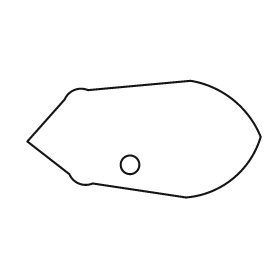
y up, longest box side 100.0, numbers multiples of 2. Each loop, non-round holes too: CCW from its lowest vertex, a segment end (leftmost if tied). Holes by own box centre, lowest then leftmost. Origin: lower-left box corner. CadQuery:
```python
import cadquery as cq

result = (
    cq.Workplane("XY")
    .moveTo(68.0, 0.0)
    .threePointArc((88.0, 8.0), (100.0, 26.0))
    .threePointArc((88.0, 42.0), (70.0, 50.0))
    .lineTo(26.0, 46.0)
    .threePointArc((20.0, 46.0), (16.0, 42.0))
    .lineTo(0.0, 24.0)
    .lineTo(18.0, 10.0)
    .threePointArc((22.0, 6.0), (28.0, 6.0))
    .close()
    .moveTo(44.0, 14.0)
    .circle(4.0)
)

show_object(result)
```